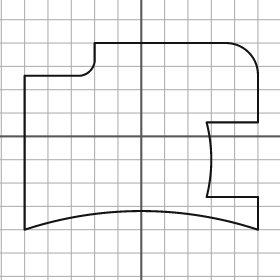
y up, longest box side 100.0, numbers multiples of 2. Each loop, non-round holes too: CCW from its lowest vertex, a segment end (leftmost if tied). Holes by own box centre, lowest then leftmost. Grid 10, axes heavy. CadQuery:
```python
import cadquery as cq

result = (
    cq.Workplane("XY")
    .moveTo(-50.0, -40.0)
    .threePointArc((0.0, -32.0), (50.0, -40.0))
    .lineTo(50.0, -26.0)
    .lineTo(28.0, -26.0)
    .threePointArc((30.0, -10.0), (28.0, 6.0))
    .lineTo(50.0, 6.0)
    .lineTo(50.0, 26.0)
    .threePointArc((46.0, 36.0), (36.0, 40.0))
    .lineTo(-20.0, 40.0)
    .lineTo(-20.0, 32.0)
    .threePointArc((-22.0, 28.0), (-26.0, 26.0))
    .lineTo(-50.0, 26.0)
    .close()
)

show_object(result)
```